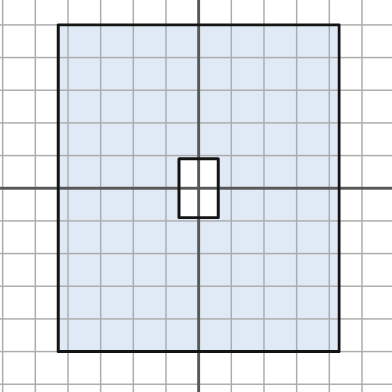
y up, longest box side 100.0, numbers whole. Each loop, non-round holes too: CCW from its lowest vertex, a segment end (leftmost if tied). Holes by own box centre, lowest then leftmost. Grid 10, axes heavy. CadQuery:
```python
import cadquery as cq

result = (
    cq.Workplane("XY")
    .moveTo(-43.0, -50.0)
    .lineTo(43.0, -50.0)
    .lineTo(43.0, 50.0)
    .lineTo(-43.0, 50.0)
    .close()
    .moveTo(-6.0, -9.0)
    .lineTo(6.0, -9.0)
    .lineTo(6.0, 9.0)
    .lineTo(-6.0, 9.0)
    .close()
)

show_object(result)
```